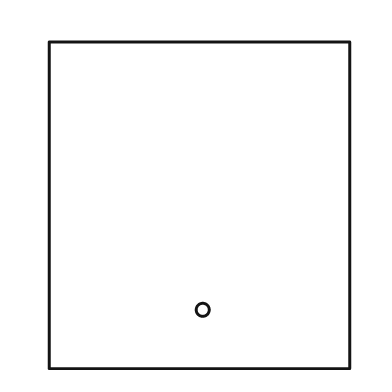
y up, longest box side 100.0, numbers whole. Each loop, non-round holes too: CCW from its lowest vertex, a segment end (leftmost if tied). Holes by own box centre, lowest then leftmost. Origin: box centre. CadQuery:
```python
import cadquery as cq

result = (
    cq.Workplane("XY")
    .moveTo(-46.0, -50.0)
    .lineTo(46.0, -50.0)
    .lineTo(46.0, 50.0)
    .lineTo(-46.0, 50.0)
    .close()
    .moveTo(1.0, -32.0)
    .circle(2.0)
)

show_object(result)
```